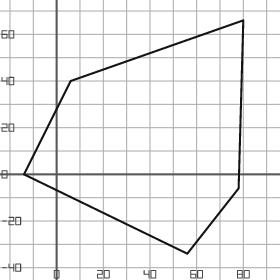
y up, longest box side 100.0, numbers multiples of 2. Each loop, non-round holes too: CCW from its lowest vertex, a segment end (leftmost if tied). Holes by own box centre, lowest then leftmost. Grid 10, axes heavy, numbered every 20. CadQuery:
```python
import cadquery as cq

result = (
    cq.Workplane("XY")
    .moveTo(56.0, -34.0)
    .lineTo(78.0, -6.0)
    .lineTo(80.0, 66.0)
    .lineTo(6.0, 40.0)
    .lineTo(-14.0, 0.0)
    .close()
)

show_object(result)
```